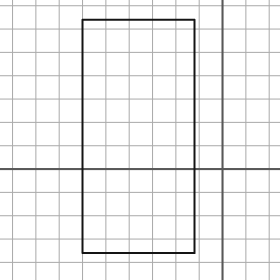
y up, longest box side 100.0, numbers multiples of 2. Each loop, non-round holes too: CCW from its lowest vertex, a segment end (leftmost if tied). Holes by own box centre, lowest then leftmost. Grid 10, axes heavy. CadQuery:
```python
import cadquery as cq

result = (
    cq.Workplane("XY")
    .moveTo(-60.0, -36.0)
    .lineTo(-12.0, -36.0)
    .lineTo(-12.0, 64.0)
    .lineTo(-60.0, 64.0)
    .close()
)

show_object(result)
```